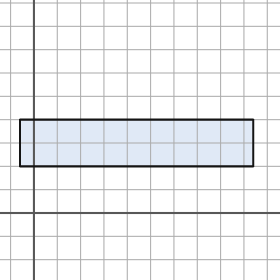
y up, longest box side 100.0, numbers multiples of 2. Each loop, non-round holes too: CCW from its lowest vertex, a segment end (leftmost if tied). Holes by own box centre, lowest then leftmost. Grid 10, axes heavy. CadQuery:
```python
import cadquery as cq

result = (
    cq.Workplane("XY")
    .moveTo(-6.0, 20.0)
    .lineTo(94.0, 20.0)
    .lineTo(94.0, 40.0)
    .lineTo(-6.0, 40.0)
    .close()
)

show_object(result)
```